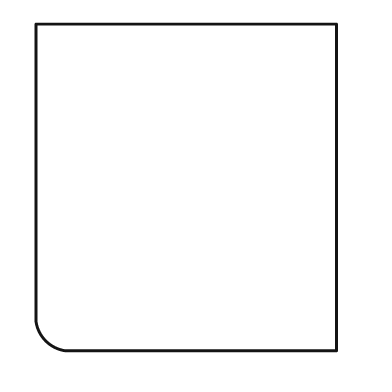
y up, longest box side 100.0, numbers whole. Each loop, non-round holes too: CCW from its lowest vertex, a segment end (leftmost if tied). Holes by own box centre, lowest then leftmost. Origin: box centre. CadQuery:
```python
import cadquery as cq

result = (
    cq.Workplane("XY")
    .moveTo(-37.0, -50.0)
    .lineTo(46.0, -50.0)
    .lineTo(46.0, 50.0)
    .lineTo(-46.0, 50.0)
    .lineTo(-46.0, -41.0)
    .threePointArc((-43.0, -47.0), (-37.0, -50.0))
    .close()
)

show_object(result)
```